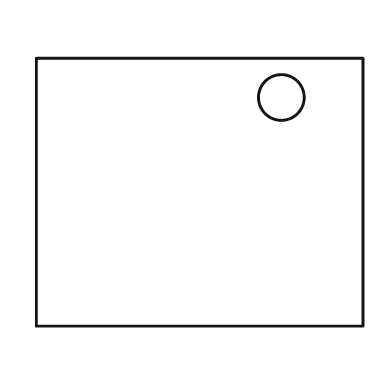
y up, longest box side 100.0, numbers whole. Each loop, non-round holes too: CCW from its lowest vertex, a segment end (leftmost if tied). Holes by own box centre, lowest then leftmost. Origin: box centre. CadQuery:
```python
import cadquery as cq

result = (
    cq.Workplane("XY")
    .moveTo(-50.0, -41.0)
    .lineTo(50.0, -41.0)
    .lineTo(50.0, 41.0)
    .lineTo(-50.0, 41.0)
    .close()
    .moveTo(25.0, 29.0)
    .circle(7.0)
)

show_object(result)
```